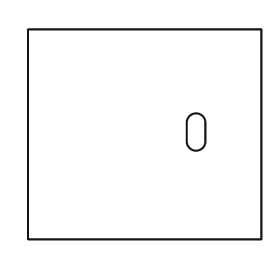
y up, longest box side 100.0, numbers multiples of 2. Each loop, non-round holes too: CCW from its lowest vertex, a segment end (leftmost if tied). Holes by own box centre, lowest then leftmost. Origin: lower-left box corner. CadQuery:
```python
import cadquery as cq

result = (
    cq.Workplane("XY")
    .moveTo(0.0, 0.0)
    .lineTo(100.0, 0.0)
    .lineTo(100.0, 90.0)
    .lineTo(0.0, 90.0)
    .close()
    .moveTo(68.0, 42.0)
    .threePointArc((72.0, 38.0), (76.0, 42.0))
    .lineTo(76.0, 50.0)
    .threePointArc((72.0, 54.0), (68.0, 50.0))
    .close()
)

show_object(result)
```